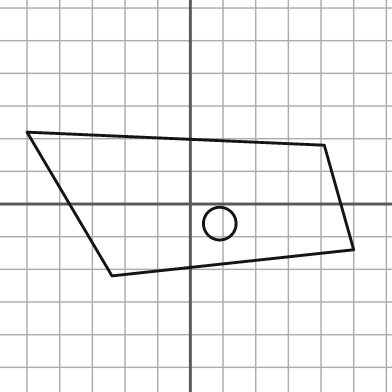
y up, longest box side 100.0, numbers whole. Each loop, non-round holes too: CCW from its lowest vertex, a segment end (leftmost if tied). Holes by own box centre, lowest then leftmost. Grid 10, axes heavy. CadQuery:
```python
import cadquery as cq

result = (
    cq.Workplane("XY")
    .moveTo(-24.0, -22.0)
    .lineTo(50.0, -14.0)
    .lineTo(41.0, 18.0)
    .lineTo(-50.0, 22.0)
    .close()
    .moveTo(9.0, -6.0)
    .circle(5.0)
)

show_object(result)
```